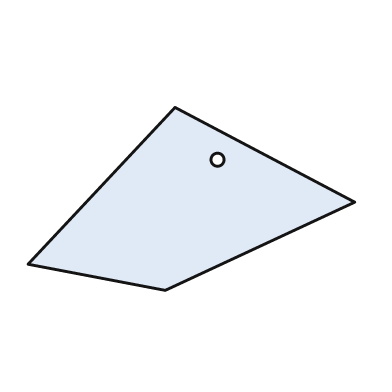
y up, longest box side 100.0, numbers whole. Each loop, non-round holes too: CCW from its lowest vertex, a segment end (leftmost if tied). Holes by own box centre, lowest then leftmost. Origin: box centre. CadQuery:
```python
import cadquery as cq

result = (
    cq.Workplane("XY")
    .moveTo(-8.0, -28.0)
    .lineTo(50.0, -1.0)
    .lineTo(-5.0, 28.0)
    .lineTo(-50.0, -20.0)
    .close()
    .moveTo(8.0, 12.0)
    .circle(2.0)
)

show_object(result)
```